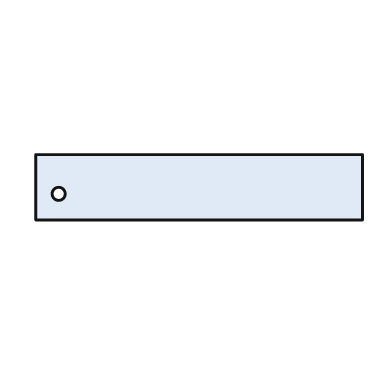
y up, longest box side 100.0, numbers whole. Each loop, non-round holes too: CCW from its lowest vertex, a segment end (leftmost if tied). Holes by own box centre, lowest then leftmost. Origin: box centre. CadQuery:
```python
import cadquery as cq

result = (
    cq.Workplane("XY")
    .moveTo(-50.0, -10.0)
    .lineTo(50.0, -10.0)
    .lineTo(50.0, 10.0)
    .lineTo(-50.0, 10.0)
    .close()
    .moveTo(-43.0, -2.0)
    .circle(2.0)
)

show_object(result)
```